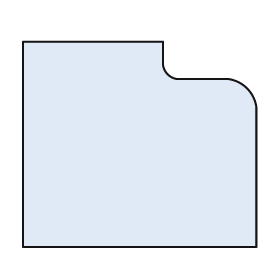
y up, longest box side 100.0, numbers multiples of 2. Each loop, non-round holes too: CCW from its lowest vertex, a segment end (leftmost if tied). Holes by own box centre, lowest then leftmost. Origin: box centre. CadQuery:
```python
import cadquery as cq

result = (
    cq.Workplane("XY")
    .moveTo(-50.0, -44.0)
    .lineTo(50.0, -44.0)
    .lineTo(50.0, 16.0)
    .threePointArc((46.0, 24.0), (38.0, 28.0))
    .lineTo(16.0, 28.0)
    .threePointArc((12.0, 30.0), (10.0, 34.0))
    .lineTo(10.0, 44.0)
    .lineTo(-50.0, 44.0)
    .close()
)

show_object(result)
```